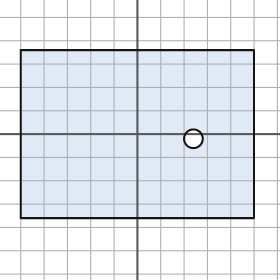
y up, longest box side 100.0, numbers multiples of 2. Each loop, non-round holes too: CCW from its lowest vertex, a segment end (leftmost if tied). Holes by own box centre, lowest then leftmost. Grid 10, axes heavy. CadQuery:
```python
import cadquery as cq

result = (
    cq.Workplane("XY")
    .moveTo(-50.0, -36.0)
    .lineTo(50.0, -36.0)
    .lineTo(50.0, 36.0)
    .lineTo(-50.0, 36.0)
    .close()
    .moveTo(24.0, -2.0)
    .circle(4.0)
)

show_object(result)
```